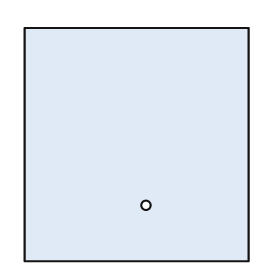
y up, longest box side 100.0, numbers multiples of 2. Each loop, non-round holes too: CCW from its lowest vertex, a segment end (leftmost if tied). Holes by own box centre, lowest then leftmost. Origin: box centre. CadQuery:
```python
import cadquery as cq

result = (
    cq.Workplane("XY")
    .moveTo(-48.0, -50.0)
    .lineTo(48.0, -50.0)
    .lineTo(48.0, 50.0)
    .lineTo(-48.0, 50.0)
    .close()
    .moveTo(4.0, -26.0)
    .circle(2.0)
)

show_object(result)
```